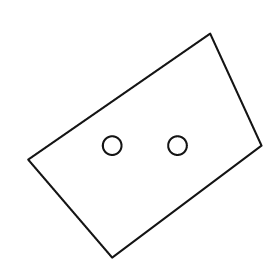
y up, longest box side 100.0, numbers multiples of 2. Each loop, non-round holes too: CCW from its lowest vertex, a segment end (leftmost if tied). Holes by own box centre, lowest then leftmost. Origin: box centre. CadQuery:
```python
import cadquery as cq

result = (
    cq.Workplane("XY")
    .moveTo(-14.0, -48.0)
    .lineTo(50.0, 0.0)
    .lineTo(28.0, 48.0)
    .lineTo(-50.0, -6.0)
    .close()
    .moveTo(-14.0, 0.0)
    .circle(4.0)
    .moveTo(14.0, 0.0)
    .circle(4.0)
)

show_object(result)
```